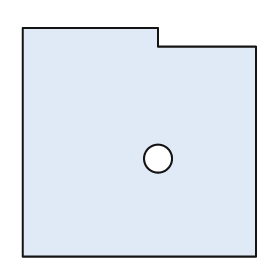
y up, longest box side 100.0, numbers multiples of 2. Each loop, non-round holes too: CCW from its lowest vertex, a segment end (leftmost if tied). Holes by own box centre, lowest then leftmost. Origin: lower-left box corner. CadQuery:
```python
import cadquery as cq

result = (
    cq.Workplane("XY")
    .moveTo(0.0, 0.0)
    .lineTo(100.0, 0.0)
    .lineTo(100.0, 90.0)
    .lineTo(58.0, 90.0)
    .lineTo(58.0, 98.0)
    .lineTo(0.0, 98.0)
    .close()
    .moveTo(58.0, 42.0)
    .circle(6.0)
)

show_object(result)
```